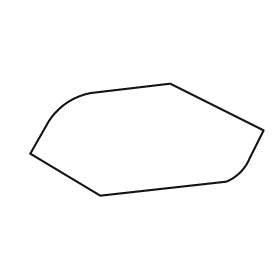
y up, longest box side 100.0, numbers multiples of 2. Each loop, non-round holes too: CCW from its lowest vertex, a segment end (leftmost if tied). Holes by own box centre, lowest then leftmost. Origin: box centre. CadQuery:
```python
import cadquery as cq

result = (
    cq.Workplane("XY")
    .moveTo(-20.0, -24.0)
    .lineTo(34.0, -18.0)
    .threePointArc((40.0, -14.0), (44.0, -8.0))
    .lineTo(50.0, 4.0)
    .lineTo(10.0, 24.0)
    .lineTo(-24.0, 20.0)
    .threePointArc((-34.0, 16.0), (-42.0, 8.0))
    .lineTo(-50.0, -6.0)
    .close()
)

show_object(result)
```